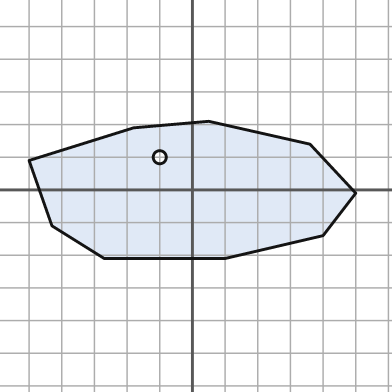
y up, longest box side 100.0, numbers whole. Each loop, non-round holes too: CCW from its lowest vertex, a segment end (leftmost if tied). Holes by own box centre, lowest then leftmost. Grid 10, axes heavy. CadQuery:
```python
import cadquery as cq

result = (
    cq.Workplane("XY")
    .moveTo(-27.0, -21.0)
    .lineTo(10.0, -21.0)
    .lineTo(40.0, -14.0)
    .lineTo(50.0, -1.0)
    .lineTo(36.0, 14.0)
    .lineTo(5.0, 21.0)
    .lineTo(-18.0, 19.0)
    .lineTo(-50.0, 9.0)
    .lineTo(-43.0, -11.0)
    .close()
    .moveTo(-10.0, 10.0)
    .circle(2.0)
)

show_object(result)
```